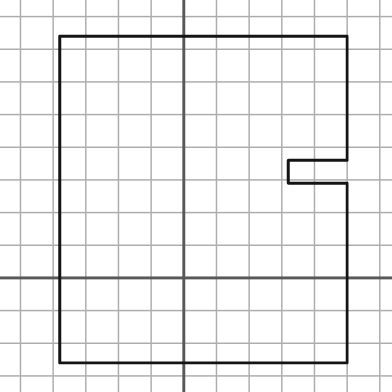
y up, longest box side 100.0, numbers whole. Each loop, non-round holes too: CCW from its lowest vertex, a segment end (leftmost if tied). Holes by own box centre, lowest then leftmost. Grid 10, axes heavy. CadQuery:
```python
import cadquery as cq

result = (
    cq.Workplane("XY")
    .moveTo(-38.0, -26.0)
    .lineTo(50.0, -26.0)
    .lineTo(50.0, 29.0)
    .lineTo(32.0, 29.0)
    .lineTo(32.0, 36.0)
    .lineTo(50.0, 36.0)
    .lineTo(50.0, 74.0)
    .lineTo(-38.0, 74.0)
    .close()
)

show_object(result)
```